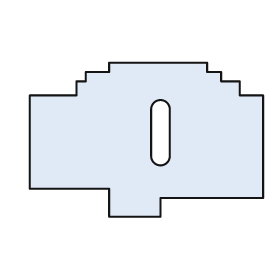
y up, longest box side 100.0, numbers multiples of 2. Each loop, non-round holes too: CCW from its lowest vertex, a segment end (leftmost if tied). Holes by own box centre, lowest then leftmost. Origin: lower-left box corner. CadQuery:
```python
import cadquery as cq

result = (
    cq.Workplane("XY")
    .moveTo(34.0, 0.0)
    .lineTo(56.0, 0.0)
    .lineTo(56.0, 8.0)
    .lineTo(100.0, 8.0)
    .lineTo(100.0, 52.0)
    .lineTo(90.0, 52.0)
    .lineTo(90.0, 58.0)
    .lineTo(82.0, 58.0)
    .lineTo(82.0, 62.0)
    .lineTo(76.0, 62.0)
    .lineTo(76.0, 66.0)
    .lineTo(34.0, 66.0)
    .lineTo(34.0, 62.0)
    .lineTo(24.0, 62.0)
    .lineTo(24.0, 58.0)
    .lineTo(20.0, 58.0)
    .lineTo(20.0, 52.0)
    .lineTo(0.0, 52.0)
    .lineTo(0.0, 12.0)
    .lineTo(34.0, 12.0)
    .close()
    .moveTo(52.0, 26.0)
    .threePointArc((56.0, 22.0), (60.0, 26.0))
    .lineTo(60.0, 46.0)
    .threePointArc((56.0, 50.0), (52.0, 46.0))
    .close()
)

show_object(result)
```